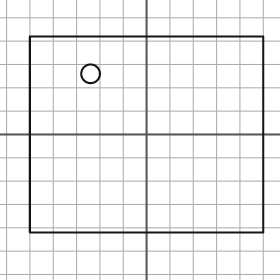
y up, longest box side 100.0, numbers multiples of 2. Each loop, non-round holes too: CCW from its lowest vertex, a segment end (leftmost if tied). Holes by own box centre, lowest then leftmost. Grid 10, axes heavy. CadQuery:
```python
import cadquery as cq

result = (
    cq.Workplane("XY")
    .moveTo(-50.0, -42.0)
    .lineTo(50.0, -42.0)
    .lineTo(50.0, 42.0)
    .lineTo(-50.0, 42.0)
    .close()
    .moveTo(-24.0, 26.0)
    .circle(4.0)
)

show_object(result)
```